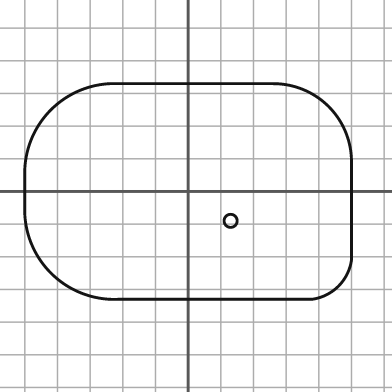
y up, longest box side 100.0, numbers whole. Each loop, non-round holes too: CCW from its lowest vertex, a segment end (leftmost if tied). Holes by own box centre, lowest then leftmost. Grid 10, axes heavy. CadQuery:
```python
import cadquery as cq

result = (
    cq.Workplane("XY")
    .moveTo(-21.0, -33.0)
    .lineTo(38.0, -33.0)
    .threePointArc((46.0, -29.0), (50.0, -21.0))
    .lineTo(50.0, 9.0)
    .threePointArc((43.0, 26.0), (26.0, 33.0))
    .lineTo(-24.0, 33.0)
    .threePointArc((-42.0, 25.0), (-50.0, 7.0))
    .lineTo(-50.0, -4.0)
    .threePointArc((-42.0, -25.0), (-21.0, -33.0))
    .close()
    .moveTo(13.0, -9.0)
    .circle(2.0)
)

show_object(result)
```